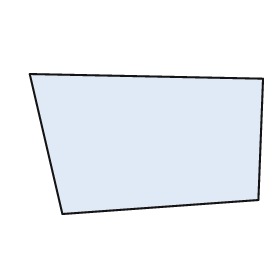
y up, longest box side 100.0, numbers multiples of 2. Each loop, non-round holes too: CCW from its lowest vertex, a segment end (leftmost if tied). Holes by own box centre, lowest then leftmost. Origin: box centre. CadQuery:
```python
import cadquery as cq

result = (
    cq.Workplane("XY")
    .moveTo(-36.0, -30.0)
    .lineTo(48.0, -24.0)
    .lineTo(50.0, 28.0)
    .lineTo(-50.0, 30.0)
    .close()
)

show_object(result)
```